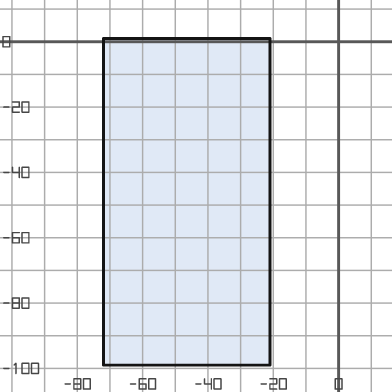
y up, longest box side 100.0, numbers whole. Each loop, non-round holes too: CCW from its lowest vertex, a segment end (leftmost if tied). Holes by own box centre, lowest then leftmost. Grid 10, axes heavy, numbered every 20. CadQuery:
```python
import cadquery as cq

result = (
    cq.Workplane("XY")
    .moveTo(-72.0, -99.0)
    .lineTo(-21.0, -99.0)
    .lineTo(-21.0, 1.0)
    .lineTo(-72.0, 1.0)
    .close()
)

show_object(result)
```